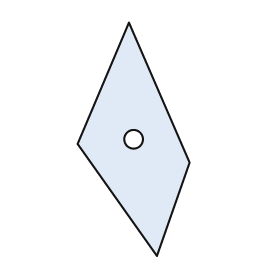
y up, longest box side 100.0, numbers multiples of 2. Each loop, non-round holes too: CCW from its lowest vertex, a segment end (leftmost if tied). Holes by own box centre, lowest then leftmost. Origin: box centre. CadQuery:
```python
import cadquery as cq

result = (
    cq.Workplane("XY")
    .moveTo(10.0, -50.0)
    .lineTo(24.0, -10.0)
    .lineTo(-2.0, 50.0)
    .lineTo(-24.0, -2.0)
    .close()
    .moveTo(0.0, 0.0)
    .circle(4.0)
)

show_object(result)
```